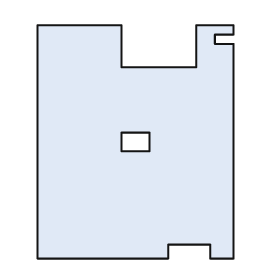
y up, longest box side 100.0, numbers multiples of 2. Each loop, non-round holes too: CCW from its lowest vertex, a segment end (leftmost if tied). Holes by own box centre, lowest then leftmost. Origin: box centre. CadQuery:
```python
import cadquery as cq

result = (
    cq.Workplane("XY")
    .moveTo(-42.0, -50.0)
    .lineTo(14.0, -50.0)
    .lineTo(14.0, -44.0)
    .lineTo(32.0, -44.0)
    .lineTo(32.0, -50.0)
    .lineTo(42.0, -50.0)
    .lineTo(42.0, 42.0)
    .lineTo(34.0, 42.0)
    .lineTo(34.0, 46.0)
    .lineTo(42.0, 46.0)
    .lineTo(42.0, 50.0)
    .lineTo(26.0, 50.0)
    .lineTo(26.0, 32.0)
    .lineTo(-6.0, 32.0)
    .lineTo(-6.0, 50.0)
    .lineTo(-42.0, 50.0)
    .close()
    .moveTo(-6.0, -4.0)
    .lineTo(6.0, -4.0)
    .lineTo(6.0, 4.0)
    .lineTo(-6.0, 4.0)
    .close()
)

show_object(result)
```